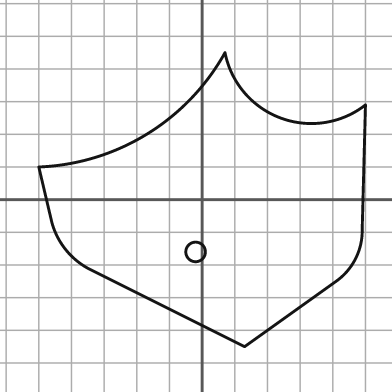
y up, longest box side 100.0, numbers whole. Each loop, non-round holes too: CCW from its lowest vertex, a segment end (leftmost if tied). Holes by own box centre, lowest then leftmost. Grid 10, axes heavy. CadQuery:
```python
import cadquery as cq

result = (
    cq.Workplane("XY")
    .moveTo(13.0, -45.0)
    .lineTo(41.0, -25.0)
    .threePointArc((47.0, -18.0), (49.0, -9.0))
    .lineTo(50.0, 29.0)
    .threePointArc((24.0, 25.0), (7.0, 45.0))
    .threePointArc((-17.0, 20.0), (-50.0, 10.0))
    .lineTo(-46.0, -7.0)
    .threePointArc((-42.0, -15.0), (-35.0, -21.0))
    .close()
    .moveTo(-2.0, -16.0)
    .circle(3.0)
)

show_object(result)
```